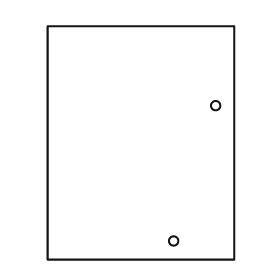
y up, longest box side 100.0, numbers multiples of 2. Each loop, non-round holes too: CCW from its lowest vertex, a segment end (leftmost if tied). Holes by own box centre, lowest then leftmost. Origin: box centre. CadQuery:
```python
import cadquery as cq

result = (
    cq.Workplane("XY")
    .moveTo(-40.0, -50.0)
    .lineTo(40.0, -50.0)
    .lineTo(40.0, 50.0)
    .lineTo(-40.0, 50.0)
    .close()
    .moveTo(14.0, -42.0)
    .circle(2.0)
    .moveTo(32.0, 16.0)
    .circle(2.0)
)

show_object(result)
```